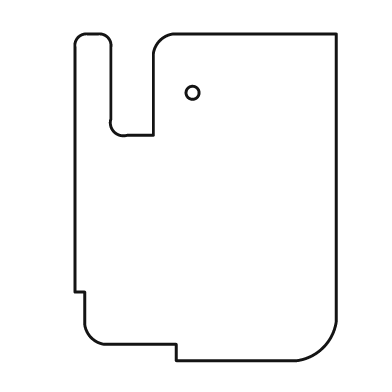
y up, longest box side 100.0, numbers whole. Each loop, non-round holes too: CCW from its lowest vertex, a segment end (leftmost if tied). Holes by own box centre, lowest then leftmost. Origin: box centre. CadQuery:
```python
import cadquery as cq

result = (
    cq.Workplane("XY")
    .moveTo(-9.0, -50.0)
    .lineTo(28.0, -50.0)
    .threePointArc((36.0, -46.0), (40.0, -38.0))
    .lineTo(40.0, 50.0)
    .lineTo(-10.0, 50.0)
    .threePointArc((-14.0, 48.0), (-16.0, 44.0))
    .lineTo(-16.0, 19.0)
    .lineTo(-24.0, 19.0)
    .threePointArc((-28.0, 20.0), (-29.0, 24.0))
    .lineTo(-29.0, 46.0)
    .threePointArc((-30.0, 49.0), (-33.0, 50.0))
    .lineTo(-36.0, 50.0)
    .threePointArc((-39.0, 49.0), (-40.0, 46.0))
    .lineTo(-40.0, -29.0)
    .lineTo(-37.0, -29.0)
    .lineTo(-37.0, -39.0)
    .threePointArc((-35.0, -43.0), (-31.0, -45.0))
    .lineTo(-9.0, -45.0)
    .close()
    .moveTo(-4.0, 32.0)
    .circle(2.0)
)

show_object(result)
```